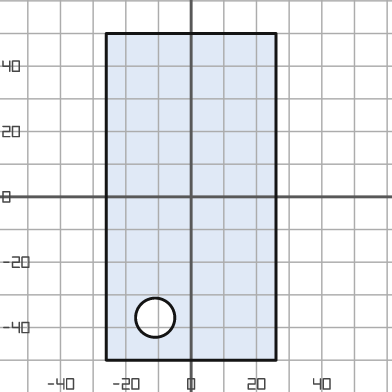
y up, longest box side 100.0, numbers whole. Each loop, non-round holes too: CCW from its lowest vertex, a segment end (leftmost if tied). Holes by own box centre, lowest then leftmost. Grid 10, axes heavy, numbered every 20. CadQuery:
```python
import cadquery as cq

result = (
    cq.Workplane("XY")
    .moveTo(-26.0, -50.0)
    .lineTo(26.0, -50.0)
    .lineTo(26.0, 50.0)
    .lineTo(-26.0, 50.0)
    .close()
    .moveTo(-11.0, -37.0)
    .circle(6.0)
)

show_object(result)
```